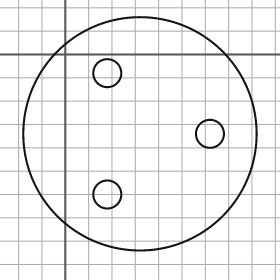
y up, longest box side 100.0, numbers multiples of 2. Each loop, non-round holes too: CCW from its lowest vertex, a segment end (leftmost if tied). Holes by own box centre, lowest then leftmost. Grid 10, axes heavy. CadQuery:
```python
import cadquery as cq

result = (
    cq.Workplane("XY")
    .moveTo(32.0, -34.0)
    .circle(50.0)
    .moveTo(18.0, -60.0)
    .circle(6.0)
    .moveTo(62.0, -34.0)
    .circle(6.0)
    .moveTo(18.0, -8.0)
    .circle(6.0)
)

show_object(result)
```